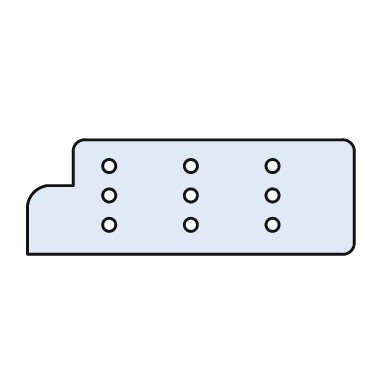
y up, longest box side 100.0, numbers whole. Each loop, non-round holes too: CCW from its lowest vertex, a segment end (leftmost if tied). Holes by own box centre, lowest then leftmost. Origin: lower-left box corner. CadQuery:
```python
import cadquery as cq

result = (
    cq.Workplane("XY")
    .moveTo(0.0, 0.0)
    .lineTo(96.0, 0.0)
    .threePointArc((99.0, 1.0), (100.0, 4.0))
    .lineTo(100.0, 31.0)
    .threePointArc((99.0, 34.0), (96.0, 35.0))
    .lineTo(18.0, 35.0)
    .threePointArc((15.0, 34.0), (14.0, 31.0))
    .lineTo(14.0, 21.0)
    .lineTo(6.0, 21.0)
    .threePointArc((2.0, 19.0), (0.0, 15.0))
    .close()
    .moveTo(25.0, 9.0)
    .circle(2.0)
    .moveTo(50.0, 9.0)
    .circle(2.0)
    .moveTo(75.0, 9.0)
    .circle(2.0)
    .moveTo(25.0, 18.0)
    .circle(2.0)
    .moveTo(50.0, 18.0)
    .circle(2.0)
    .moveTo(75.0, 18.0)
    .circle(2.0)
    .moveTo(25.0, 27.0)
    .circle(2.0)
    .moveTo(50.0, 27.0)
    .circle(2.0)
    .moveTo(75.0, 27.0)
    .circle(2.0)
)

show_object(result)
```